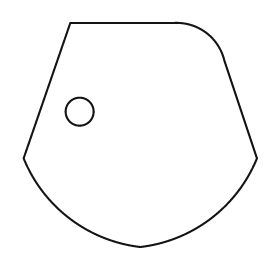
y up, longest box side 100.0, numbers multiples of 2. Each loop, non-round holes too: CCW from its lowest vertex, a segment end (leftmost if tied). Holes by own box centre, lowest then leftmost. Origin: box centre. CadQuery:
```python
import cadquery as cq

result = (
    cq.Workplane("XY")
    .moveTo(0.0, -48.0)
    .threePointArc((30.0, -36.0), (50.0, -10.0))
    .lineTo(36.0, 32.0)
    .threePointArc((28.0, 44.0), (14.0, 48.0))
    .lineTo(-30.0, 48.0)
    .lineTo(-50.0, -10.0)
    .threePointArc((-30.0, -36.0), (0.0, -48.0))
    .close()
    .moveTo(-26.0, 10.0)
    .circle(6.0)
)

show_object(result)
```